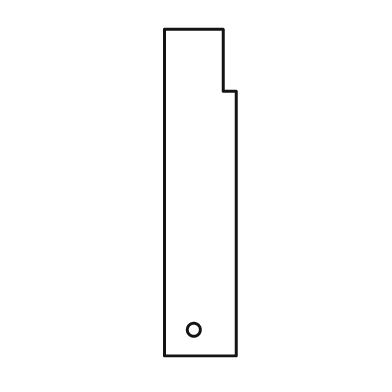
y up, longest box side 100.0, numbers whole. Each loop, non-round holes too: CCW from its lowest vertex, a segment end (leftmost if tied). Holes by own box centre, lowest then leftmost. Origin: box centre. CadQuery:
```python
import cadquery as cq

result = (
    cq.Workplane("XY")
    .moveTo(-11.0, -50.0)
    .lineTo(11.0, -50.0)
    .lineTo(11.0, 31.0)
    .lineTo(7.0, 31.0)
    .lineTo(7.0, 50.0)
    .lineTo(-11.0, 50.0)
    .close()
    .moveTo(-2.0, -42.0)
    .circle(2.0)
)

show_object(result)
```